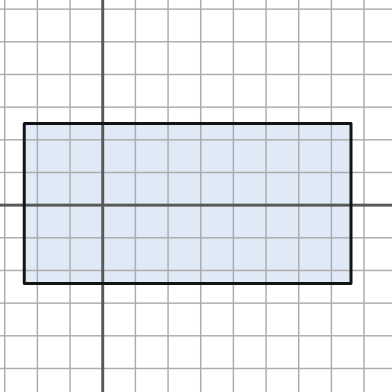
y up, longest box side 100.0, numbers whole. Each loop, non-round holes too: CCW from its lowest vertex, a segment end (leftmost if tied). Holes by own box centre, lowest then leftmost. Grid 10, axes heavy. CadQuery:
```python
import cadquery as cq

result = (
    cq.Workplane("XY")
    .moveTo(-24.0, -24.0)
    .lineTo(76.0, -24.0)
    .lineTo(76.0, 25.0)
    .lineTo(-24.0, 25.0)
    .close()
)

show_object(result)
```